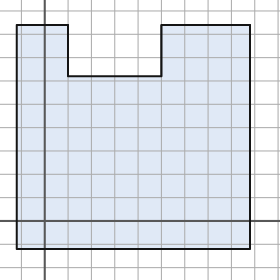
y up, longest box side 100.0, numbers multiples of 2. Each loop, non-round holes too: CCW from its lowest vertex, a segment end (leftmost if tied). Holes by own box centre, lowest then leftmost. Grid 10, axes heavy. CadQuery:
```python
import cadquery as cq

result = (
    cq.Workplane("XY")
    .moveTo(-12.0, -12.0)
    .lineTo(88.0, -12.0)
    .lineTo(88.0, 84.0)
    .lineTo(50.0, 84.0)
    .lineTo(50.0, 62.0)
    .lineTo(10.0, 62.0)
    .lineTo(10.0, 84.0)
    .lineTo(-12.0, 84.0)
    .close()
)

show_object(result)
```